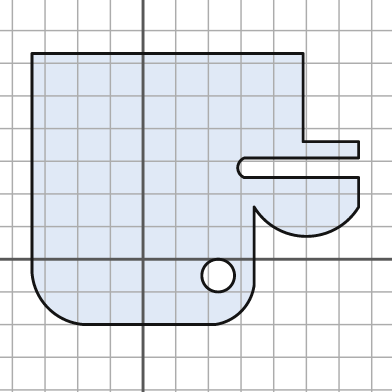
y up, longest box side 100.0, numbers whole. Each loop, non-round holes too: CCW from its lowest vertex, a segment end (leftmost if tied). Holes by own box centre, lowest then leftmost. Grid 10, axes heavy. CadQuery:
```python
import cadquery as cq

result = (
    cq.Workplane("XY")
    .moveTo(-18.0, -20.0)
    .lineTo(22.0, -20.0)
    .threePointArc((30.0, -16.0), (34.0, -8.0))
    .lineTo(34.0, 16.0)
    .threePointArc((50.0, 7.0), (66.0, 16.0))
    .lineTo(66.0, 25.0)
    .lineTo(31.0, 25.0)
    .threePointArc((29.0, 28.0), (31.0, 31.0))
    .lineTo(66.0, 31.0)
    .lineTo(66.0, 36.0)
    .lineTo(49.0, 36.0)
    .lineTo(49.0, 63.0)
    .lineTo(-34.0, 63.0)
    .lineTo(-34.0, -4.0)
    .threePointArc((-29.0, -15.0), (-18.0, -20.0))
    .close()
    .moveTo(23.0, -5.0)
    .circle(5.0)
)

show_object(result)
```